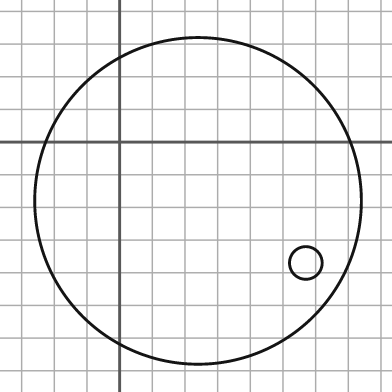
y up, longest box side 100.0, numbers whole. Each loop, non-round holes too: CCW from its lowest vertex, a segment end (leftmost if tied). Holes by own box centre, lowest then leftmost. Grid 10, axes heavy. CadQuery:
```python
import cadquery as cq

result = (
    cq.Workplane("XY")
    .moveTo(24.0, -18.0)
    .circle(50.0)
    .moveTo(57.0, -37.0)
    .circle(5.0)
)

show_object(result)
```